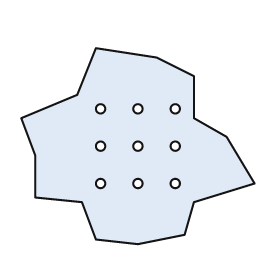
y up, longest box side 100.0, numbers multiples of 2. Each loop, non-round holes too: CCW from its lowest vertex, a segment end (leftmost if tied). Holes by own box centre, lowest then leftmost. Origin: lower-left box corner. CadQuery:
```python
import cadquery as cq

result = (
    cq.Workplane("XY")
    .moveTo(50.0, 0.0)
    .lineTo(70.0, 4.0)
    .lineTo(74.0, 18.0)
    .lineTo(100.0, 26.0)
    .lineTo(88.0, 46.0)
    .lineTo(74.0, 54.0)
    .lineTo(74.0, 72.0)
    .lineTo(58.0, 80.0)
    .lineTo(32.0, 84.0)
    .lineTo(24.0, 64.0)
    .lineTo(0.0, 54.0)
    .lineTo(6.0, 38.0)
    .lineTo(6.0, 20.0)
    .lineTo(26.0, 18.0)
    .lineTo(32.0, 2.0)
    .close()
    .moveTo(34.0, 26.0)
    .circle(2.0)
    .moveTo(50.0, 26.0)
    .circle(2.0)
    .moveTo(66.0, 26.0)
    .circle(2.0)
    .moveTo(34.0, 42.0)
    .circle(2.0)
    .moveTo(50.0, 42.0)
    .circle(2.0)
    .moveTo(66.0, 42.0)
    .circle(2.0)
    .moveTo(34.0, 58.0)
    .circle(2.0)
    .moveTo(50.0, 58.0)
    .circle(2.0)
    .moveTo(66.0, 58.0)
    .circle(2.0)
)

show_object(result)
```